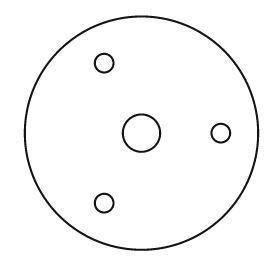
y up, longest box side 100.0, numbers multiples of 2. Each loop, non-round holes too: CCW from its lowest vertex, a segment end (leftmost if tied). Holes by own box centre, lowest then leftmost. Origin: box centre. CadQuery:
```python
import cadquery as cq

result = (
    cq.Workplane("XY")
    .moveTo(0.0, 0.0)
    .circle(50.0)
    .moveTo(-16.0, -30.0)
    .circle(4.0)
    .moveTo(0.0, 0.0)
    .circle(8.0)
    .moveTo(34.0, 0.0)
    .circle(4.0)
    .moveTo(-16.0, 30.0)
    .circle(4.0)
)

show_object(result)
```